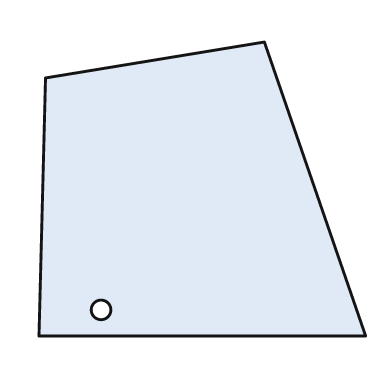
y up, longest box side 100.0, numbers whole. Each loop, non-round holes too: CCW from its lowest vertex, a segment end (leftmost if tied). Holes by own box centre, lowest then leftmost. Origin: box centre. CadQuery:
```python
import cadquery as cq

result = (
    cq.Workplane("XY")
    .moveTo(-50.0, -45.0)
    .lineTo(50.0, -45.0)
    .lineTo(19.0, 45.0)
    .lineTo(-48.0, 34.0)
    .close()
    .moveTo(-31.0, -37.0)
    .circle(3.0)
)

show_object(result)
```